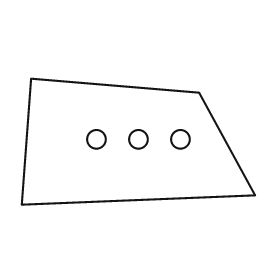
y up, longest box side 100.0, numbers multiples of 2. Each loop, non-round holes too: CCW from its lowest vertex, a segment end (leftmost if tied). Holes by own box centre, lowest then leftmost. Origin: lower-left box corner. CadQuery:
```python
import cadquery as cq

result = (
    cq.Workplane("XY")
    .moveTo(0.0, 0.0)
    .lineTo(100.0, 4.0)
    .lineTo(76.0, 48.0)
    .lineTo(4.0, 54.0)
    .close()
    .moveTo(32.0, 28.0)
    .circle(4.0)
    .moveTo(50.0, 28.0)
    .circle(4.0)
    .moveTo(68.0, 28.0)
    .circle(4.0)
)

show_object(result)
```